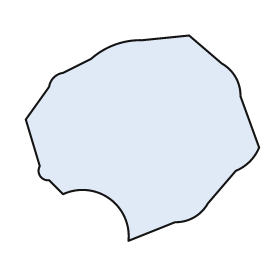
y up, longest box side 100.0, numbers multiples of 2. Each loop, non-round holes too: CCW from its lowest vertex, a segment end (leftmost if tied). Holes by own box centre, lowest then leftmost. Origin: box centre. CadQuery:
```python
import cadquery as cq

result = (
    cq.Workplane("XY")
    .moveTo(-6.0, -44.0)
    .lineTo(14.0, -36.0)
    .threePointArc((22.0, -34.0), (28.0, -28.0))
    .lineTo(40.0, -14.0)
    .threePointArc((46.0, -10.0), (50.0, -4.0))
    .lineTo(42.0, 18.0)
    .threePointArc((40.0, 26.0), (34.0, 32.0))
    .lineTo(20.0, 44.0)
    .lineTo(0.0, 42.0)
    .threePointArc((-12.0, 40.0), (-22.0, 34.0))
    .lineTo(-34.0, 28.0)
    .threePointArc((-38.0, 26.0), (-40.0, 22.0))
    .lineTo(-50.0, 8.0)
    .lineTo(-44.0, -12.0)
    .threePointArc((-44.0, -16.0), (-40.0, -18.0))
    .lineTo(-34.0, -24.0)
    .threePointArc((-14.0, -26.0), (-6.0, -44.0))
    .close()
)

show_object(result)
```